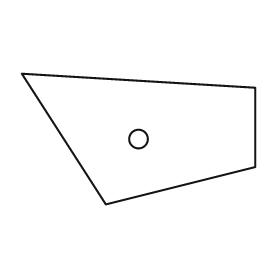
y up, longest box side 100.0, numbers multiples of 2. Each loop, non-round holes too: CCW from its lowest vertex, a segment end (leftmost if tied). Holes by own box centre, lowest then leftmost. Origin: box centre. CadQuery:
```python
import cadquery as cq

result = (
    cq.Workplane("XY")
    .moveTo(-14.0, -28.0)
    .lineTo(50.0, -12.0)
    .lineTo(50.0, 22.0)
    .lineTo(-50.0, 28.0)
    .close()
    .moveTo(0.0, 0.0)
    .circle(4.0)
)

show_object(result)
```